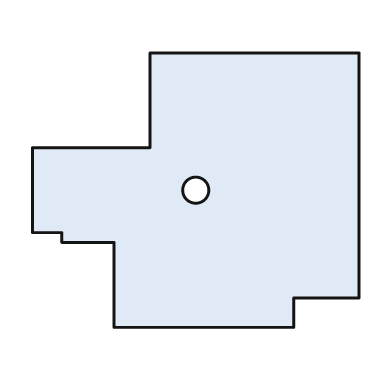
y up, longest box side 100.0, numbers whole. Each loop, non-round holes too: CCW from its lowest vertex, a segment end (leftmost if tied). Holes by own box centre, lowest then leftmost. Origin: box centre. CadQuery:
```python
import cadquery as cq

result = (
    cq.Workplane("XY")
    .moveTo(-25.0, -42.0)
    .lineTo(30.0, -42.0)
    .lineTo(30.0, -33.0)
    .lineTo(50.0, -33.0)
    .lineTo(50.0, 42.0)
    .lineTo(-14.0, 42.0)
    .lineTo(-14.0, 13.0)
    .lineTo(-50.0, 13.0)
    .lineTo(-50.0, -13.0)
    .lineTo(-41.0, -13.0)
    .lineTo(-41.0, -16.0)
    .lineTo(-25.0, -16.0)
    .close()
    .moveTo(0.0, 0.0)
    .circle(4.0)
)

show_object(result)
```